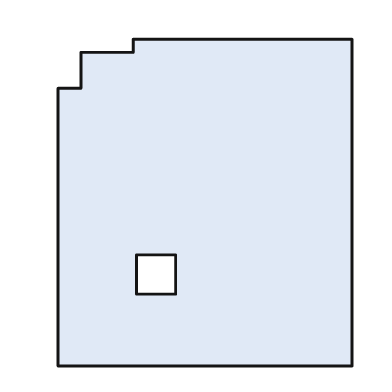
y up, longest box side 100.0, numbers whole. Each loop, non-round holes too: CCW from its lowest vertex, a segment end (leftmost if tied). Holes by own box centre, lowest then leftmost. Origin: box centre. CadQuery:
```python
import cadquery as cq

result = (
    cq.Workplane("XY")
    .moveTo(-45.0, -50.0)
    .lineTo(45.0, -50.0)
    .lineTo(45.0, 50.0)
    .lineTo(-22.0, 50.0)
    .lineTo(-22.0, 46.0)
    .lineTo(-38.0, 46.0)
    .lineTo(-38.0, 35.0)
    .lineTo(-45.0, 35.0)
    .close()
    .moveTo(-21.0, -28.0)
    .lineTo(-9.0, -28.0)
    .lineTo(-9.0, -16.0)
    .lineTo(-21.0, -16.0)
    .close()
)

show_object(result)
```